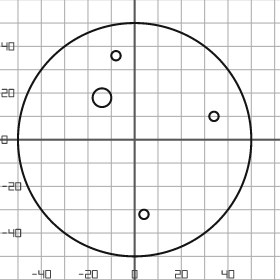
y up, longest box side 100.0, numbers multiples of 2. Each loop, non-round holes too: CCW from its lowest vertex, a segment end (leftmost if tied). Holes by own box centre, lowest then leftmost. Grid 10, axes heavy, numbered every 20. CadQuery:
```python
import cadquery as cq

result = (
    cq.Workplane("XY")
    .moveTo(0.0, 0.0)
    .circle(50.0)
    .moveTo(4.0, -32.0)
    .circle(2.0)
    .moveTo(34.0, 10.0)
    .circle(2.0)
    .moveTo(-14.0, 18.0)
    .circle(4.0)
    .moveTo(-8.0, 36.0)
    .circle(2.0)
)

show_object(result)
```